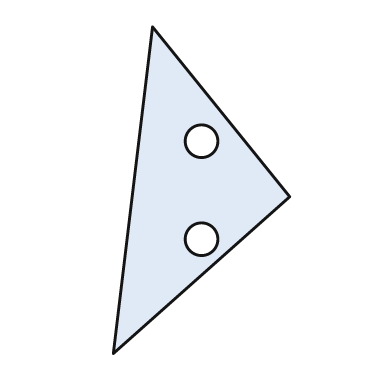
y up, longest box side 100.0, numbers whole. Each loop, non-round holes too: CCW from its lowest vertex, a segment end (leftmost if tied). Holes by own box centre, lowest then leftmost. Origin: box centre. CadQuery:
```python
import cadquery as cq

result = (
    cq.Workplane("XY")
    .moveTo(-27.0, -50.0)
    .lineTo(27.0, -2.0)
    .lineTo(-15.0, 50.0)
    .close()
    .moveTo(0.0, -15.0)
    .circle(5.0)
    .moveTo(0.0, 15.0)
    .circle(5.0)
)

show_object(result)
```